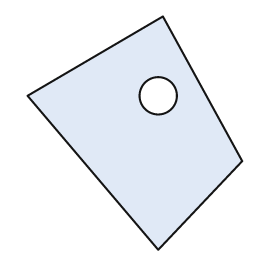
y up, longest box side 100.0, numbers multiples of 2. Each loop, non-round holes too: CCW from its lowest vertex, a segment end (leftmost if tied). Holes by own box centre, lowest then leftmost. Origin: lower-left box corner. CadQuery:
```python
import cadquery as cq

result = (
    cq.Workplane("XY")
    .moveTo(56.0, 0.0)
    .lineTo(92.0, 38.0)
    .lineTo(58.0, 100.0)
    .lineTo(0.0, 66.0)
    .close()
    .moveTo(56.0, 66.0)
    .circle(8.0)
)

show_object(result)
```